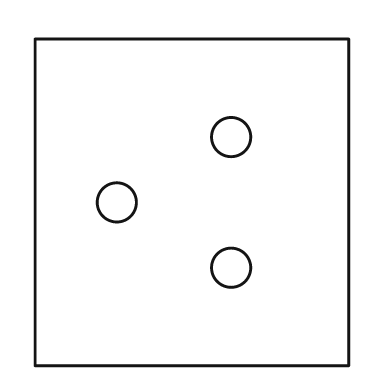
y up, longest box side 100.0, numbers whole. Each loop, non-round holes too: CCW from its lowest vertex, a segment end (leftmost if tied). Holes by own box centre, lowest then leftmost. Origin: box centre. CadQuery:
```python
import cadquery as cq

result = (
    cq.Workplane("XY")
    .moveTo(-48.0, -50.0)
    .lineTo(48.0, -50.0)
    .lineTo(48.0, 50.0)
    .lineTo(-48.0, 50.0)
    .close()
    .moveTo(12.0, -20.0)
    .circle(6.0)
    .moveTo(-23.0, 0.0)
    .circle(6.0)
    .moveTo(12.0, 20.0)
    .circle(6.0)
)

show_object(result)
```